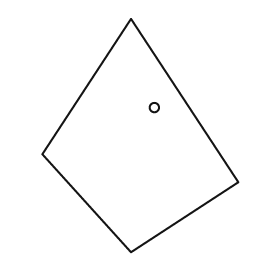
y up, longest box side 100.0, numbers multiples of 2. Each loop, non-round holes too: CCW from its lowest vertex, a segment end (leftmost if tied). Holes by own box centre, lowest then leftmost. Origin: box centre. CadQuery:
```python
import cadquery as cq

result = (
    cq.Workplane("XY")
    .moveTo(-4.0, -50.0)
    .lineTo(42.0, -20.0)
    .lineTo(-4.0, 50.0)
    .lineTo(-42.0, -8.0)
    .close()
    .moveTo(6.0, 12.0)
    .circle(2.0)
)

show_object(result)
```